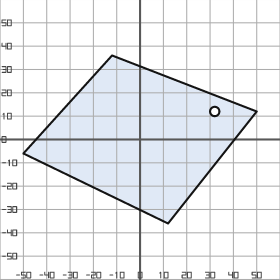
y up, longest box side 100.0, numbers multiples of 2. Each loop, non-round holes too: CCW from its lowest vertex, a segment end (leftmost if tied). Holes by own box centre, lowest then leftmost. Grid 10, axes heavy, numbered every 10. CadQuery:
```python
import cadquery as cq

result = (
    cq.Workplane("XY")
    .moveTo(12.0, -36.0)
    .lineTo(50.0, 12.0)
    .lineTo(-12.0, 36.0)
    .lineTo(-50.0, -6.0)
    .close()
    .moveTo(32.0, 12.0)
    .circle(2.0)
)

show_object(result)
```